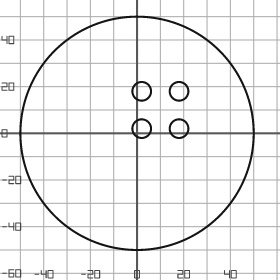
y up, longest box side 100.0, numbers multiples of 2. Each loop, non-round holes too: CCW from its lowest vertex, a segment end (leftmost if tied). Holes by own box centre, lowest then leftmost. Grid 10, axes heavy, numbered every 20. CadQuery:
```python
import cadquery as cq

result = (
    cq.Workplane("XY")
    .moveTo(0.0, 0.0)
    .circle(50.0)
    .moveTo(2.0, 2.0)
    .circle(4.0)
    .moveTo(18.0, 2.0)
    .circle(4.0)
    .moveTo(2.0, 18.0)
    .circle(4.0)
    .moveTo(18.0, 18.0)
    .circle(4.0)
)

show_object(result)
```